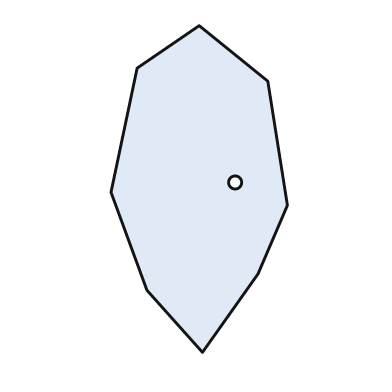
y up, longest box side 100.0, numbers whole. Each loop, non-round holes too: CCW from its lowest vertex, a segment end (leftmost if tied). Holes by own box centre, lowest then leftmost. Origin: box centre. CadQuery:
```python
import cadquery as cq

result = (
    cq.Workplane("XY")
    .moveTo(1.0, -50.0)
    .lineTo(18.0, -26.0)
    .lineTo(27.0, -5.0)
    .lineTo(21.0, 33.0)
    .lineTo(0.0, 50.0)
    .lineTo(-19.0, 37.0)
    .lineTo(-27.0, -1.0)
    .lineTo(-16.0, -31.0)
    .close()
    .moveTo(11.0, 2.0)
    .circle(2.0)
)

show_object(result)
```